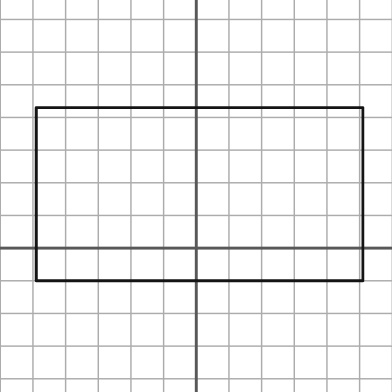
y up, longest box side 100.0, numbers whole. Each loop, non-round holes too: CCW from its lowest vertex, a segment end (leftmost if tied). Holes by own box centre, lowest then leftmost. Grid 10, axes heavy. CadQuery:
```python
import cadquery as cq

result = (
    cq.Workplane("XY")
    .moveTo(-49.0, -10.0)
    .lineTo(51.0, -10.0)
    .lineTo(51.0, 43.0)
    .lineTo(-49.0, 43.0)
    .close()
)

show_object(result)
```